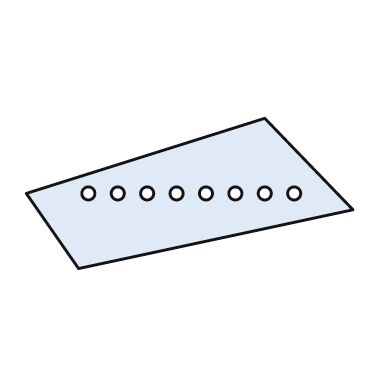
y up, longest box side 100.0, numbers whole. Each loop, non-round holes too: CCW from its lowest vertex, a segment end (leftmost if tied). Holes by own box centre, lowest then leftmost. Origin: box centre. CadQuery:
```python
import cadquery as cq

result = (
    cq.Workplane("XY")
    .moveTo(-34.0, -23.0)
    .lineTo(50.0, -5.0)
    .lineTo(23.0, 23.0)
    .lineTo(-50.0, 0.0)
    .close()
    .moveTo(-31.0, 0.0)
    .circle(2.0)
    .moveTo(-22.0, 0.0)
    .circle(2.0)
    .moveTo(-13.0, 0.0)
    .circle(2.0)
    .moveTo(-4.0, 0.0)
    .circle(2.0)
    .moveTo(5.0, 0.0)
    .circle(2.0)
    .moveTo(14.0, 0.0)
    .circle(2.0)
    .moveTo(23.0, 0.0)
    .circle(2.0)
    .moveTo(32.0, 0.0)
    .circle(2.0)
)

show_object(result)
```